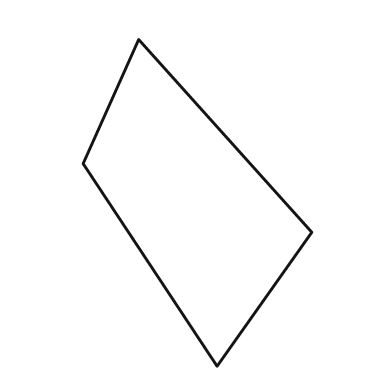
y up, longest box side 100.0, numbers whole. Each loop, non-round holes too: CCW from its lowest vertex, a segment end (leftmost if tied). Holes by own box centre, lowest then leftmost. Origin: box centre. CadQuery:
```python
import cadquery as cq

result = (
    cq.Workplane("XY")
    .moveTo(6.0, -50.0)
    .lineTo(35.0, -9.0)
    .lineTo(-18.0, 50.0)
    .lineTo(-35.0, 12.0)
    .close()
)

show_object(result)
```